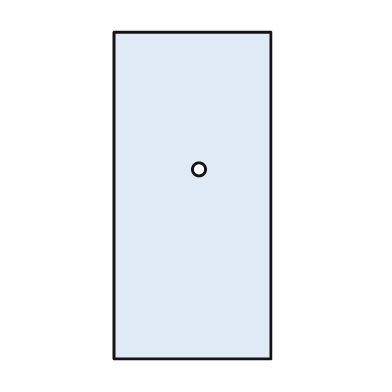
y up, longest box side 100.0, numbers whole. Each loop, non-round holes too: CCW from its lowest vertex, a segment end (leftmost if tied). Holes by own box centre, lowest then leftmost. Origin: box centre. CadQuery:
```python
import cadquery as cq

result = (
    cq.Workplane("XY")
    .moveTo(-24.0, -50.0)
    .lineTo(24.0, -50.0)
    .lineTo(24.0, 50.0)
    .lineTo(-24.0, 50.0)
    .close()
    .moveTo(2.0, 8.0)
    .circle(2.0)
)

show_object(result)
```